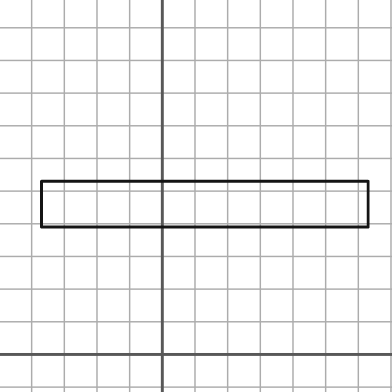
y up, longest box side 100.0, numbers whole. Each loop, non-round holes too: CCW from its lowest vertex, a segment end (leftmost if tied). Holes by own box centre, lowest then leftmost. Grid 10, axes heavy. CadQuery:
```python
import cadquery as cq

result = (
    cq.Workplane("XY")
    .moveTo(-37.0, 39.0)
    .lineTo(63.0, 39.0)
    .lineTo(63.0, 53.0)
    .lineTo(-37.0, 53.0)
    .close()
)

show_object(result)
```